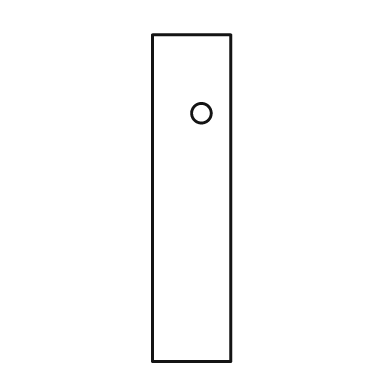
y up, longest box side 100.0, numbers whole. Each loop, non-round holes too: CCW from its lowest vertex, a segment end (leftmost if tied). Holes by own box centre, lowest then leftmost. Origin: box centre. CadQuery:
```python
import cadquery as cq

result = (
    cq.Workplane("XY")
    .moveTo(-12.0, -50.0)
    .lineTo(12.0, -50.0)
    .lineTo(12.0, 50.0)
    .lineTo(-12.0, 50.0)
    .close()
    .moveTo(3.0, 26.0)
    .circle(3.0)
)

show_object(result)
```